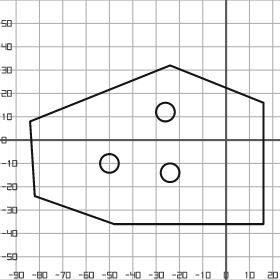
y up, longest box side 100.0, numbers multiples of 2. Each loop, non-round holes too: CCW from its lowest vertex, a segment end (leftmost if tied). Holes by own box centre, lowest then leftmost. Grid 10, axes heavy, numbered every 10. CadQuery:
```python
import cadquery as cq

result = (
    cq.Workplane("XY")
    .moveTo(-48.0, -36.0)
    .lineTo(16.0, -36.0)
    .lineTo(16.0, 16.0)
    .lineTo(-24.0, 32.0)
    .lineTo(-84.0, 8.0)
    .lineTo(-82.0, -24.0)
    .close()
    .moveTo(-24.0, -14.0)
    .circle(4.0)
    .moveTo(-50.0, -10.0)
    .circle(4.0)
    .moveTo(-26.0, 12.0)
    .circle(4.0)
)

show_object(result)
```